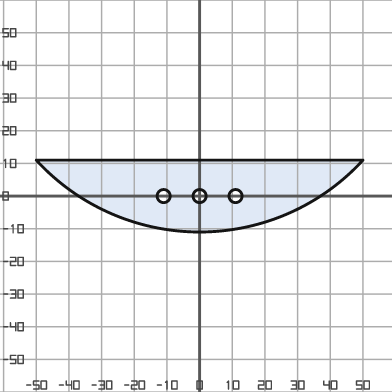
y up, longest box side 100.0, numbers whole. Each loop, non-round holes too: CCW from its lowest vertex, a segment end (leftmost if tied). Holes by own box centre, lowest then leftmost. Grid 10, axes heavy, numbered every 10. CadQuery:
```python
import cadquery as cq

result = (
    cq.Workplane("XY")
    .moveTo(-50.0, 11.0)
    .threePointArc((0.0, -11.0), (50.0, 11.0))
    .close()
    .moveTo(-11.0, 0.0)
    .circle(2.0)
    .moveTo(0.0, 0.0)
    .circle(2.0)
    .moveTo(11.0, 0.0)
    .circle(2.0)
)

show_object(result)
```